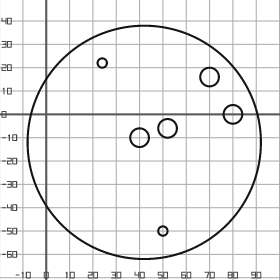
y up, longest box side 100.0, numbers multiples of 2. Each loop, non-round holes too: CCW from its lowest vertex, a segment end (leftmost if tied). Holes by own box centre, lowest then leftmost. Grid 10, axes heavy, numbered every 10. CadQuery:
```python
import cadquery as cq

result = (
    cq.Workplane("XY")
    .moveTo(42.0, -12.0)
    .circle(50.0)
    .moveTo(50.0, -50.0)
    .circle(2.0)
    .moveTo(40.0, -10.0)
    .circle(4.0)
    .moveTo(52.0, -6.0)
    .circle(4.0)
    .moveTo(80.0, 0.0)
    .circle(4.0)
    .moveTo(70.0, 16.0)
    .circle(4.0)
    .moveTo(24.0, 22.0)
    .circle(2.0)
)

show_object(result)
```